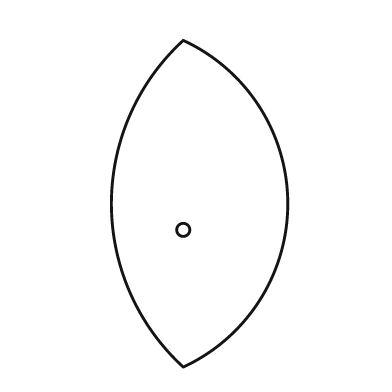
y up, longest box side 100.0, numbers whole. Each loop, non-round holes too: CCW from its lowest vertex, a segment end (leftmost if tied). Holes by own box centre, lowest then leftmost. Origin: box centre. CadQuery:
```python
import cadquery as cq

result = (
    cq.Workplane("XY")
    .moveTo(-5.0, -50.0)
    .threePointArc((27.0, 0.0), (-5.0, 50.0))
    .threePointArc((-27.0, 0.0), (-5.0, -50.0))
    .close()
    .moveTo(-5.0, -8.0)
    .circle(2.0)
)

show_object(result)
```